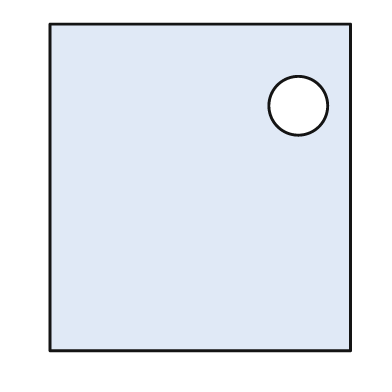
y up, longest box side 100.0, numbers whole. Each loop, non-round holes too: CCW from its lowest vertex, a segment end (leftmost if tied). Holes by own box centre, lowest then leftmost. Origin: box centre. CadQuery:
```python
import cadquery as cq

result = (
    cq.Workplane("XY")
    .moveTo(-46.0, -50.0)
    .lineTo(46.0, -50.0)
    .lineTo(46.0, 50.0)
    .lineTo(-46.0, 50.0)
    .close()
    .moveTo(30.0, 25.0)
    .circle(9.0)
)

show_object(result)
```